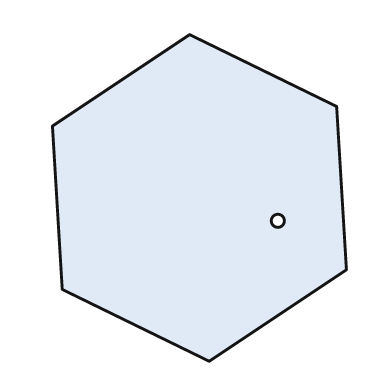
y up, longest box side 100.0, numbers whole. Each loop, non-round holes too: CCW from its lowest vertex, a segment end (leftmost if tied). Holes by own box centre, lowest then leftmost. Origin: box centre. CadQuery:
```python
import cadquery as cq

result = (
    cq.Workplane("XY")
    .moveTo(3.0, -50.0)
    .lineTo(45.0, -22.0)
    .lineTo(42.0, 28.0)
    .lineTo(-3.0, 50.0)
    .lineTo(-45.0, 22.0)
    .lineTo(-42.0, -28.0)
    .close()
    .moveTo(24.0, -7.0)
    .circle(2.0)
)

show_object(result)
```